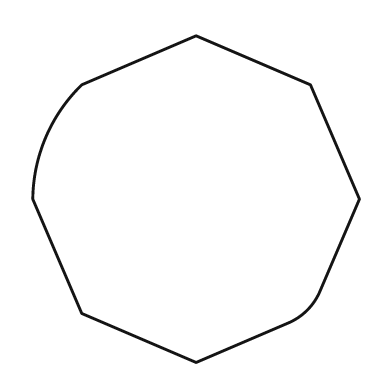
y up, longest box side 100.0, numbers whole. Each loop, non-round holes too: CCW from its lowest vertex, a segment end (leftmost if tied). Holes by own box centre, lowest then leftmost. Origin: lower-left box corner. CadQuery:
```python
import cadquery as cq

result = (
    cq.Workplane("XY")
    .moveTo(50.0, 0.0)
    .lineTo(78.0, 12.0)
    .threePointArc((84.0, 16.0), (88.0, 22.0))
    .lineTo(100.0, 50.0)
    .lineTo(85.0, 85.0)
    .lineTo(50.0, 100.0)
    .lineTo(15.0, 85.0)
    .threePointArc((4.0, 69.0), (0.0, 50.0))
    .lineTo(15.0, 15.0)
    .close()
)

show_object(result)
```